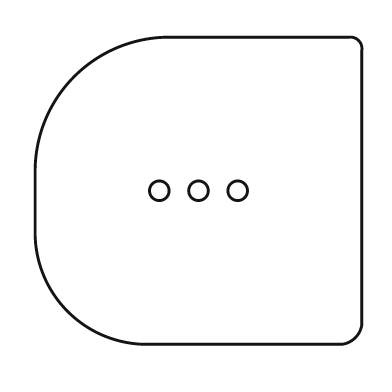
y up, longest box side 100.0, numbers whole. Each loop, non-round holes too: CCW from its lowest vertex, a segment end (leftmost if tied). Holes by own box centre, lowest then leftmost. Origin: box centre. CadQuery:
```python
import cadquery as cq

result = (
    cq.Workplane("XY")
    .moveTo(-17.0, -47.0)
    .lineTo(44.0, -47.0)
    .threePointArc((48.0, -45.0), (50.0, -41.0))
    .lineTo(50.0, 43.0)
    .threePointArc((49.0, 46.0), (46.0, 47.0))
    .lineTo(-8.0, 47.0)
    .threePointArc((-38.0, 35.0), (-50.0, 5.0))
    .lineTo(-50.0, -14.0)
    .threePointArc((-40.0, -37.0), (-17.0, -47.0))
    .close()
    .moveTo(-12.0, 0.0)
    .circle(3.0)
    .moveTo(0.0, 0.0)
    .circle(3.0)
    .moveTo(12.0, 0.0)
    .circle(3.0)
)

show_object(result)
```